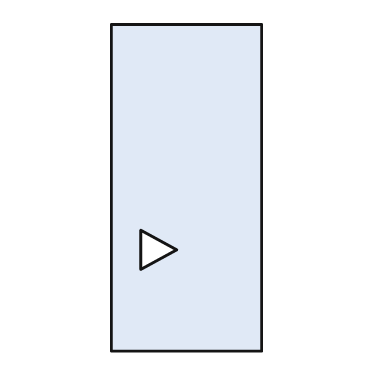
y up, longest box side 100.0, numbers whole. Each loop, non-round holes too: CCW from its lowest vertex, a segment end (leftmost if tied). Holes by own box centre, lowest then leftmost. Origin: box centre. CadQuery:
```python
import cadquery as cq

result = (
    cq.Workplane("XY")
    .moveTo(-23.0, -50.0)
    .lineTo(23.0, -50.0)
    .lineTo(23.0, 50.0)
    .lineTo(-23.0, 50.0)
    .close()
    .moveTo(-14.0, -25.0)
    .lineTo(-3.0, -19.0)
    .lineTo(-14.0, -13.0)
    .close()
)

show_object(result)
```